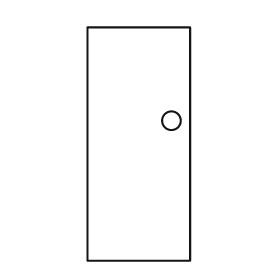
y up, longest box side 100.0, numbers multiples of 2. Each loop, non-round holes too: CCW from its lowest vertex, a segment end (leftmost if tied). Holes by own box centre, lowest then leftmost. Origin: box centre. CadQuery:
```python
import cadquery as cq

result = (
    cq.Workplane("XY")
    .moveTo(-22.0, -50.0)
    .lineTo(22.0, -50.0)
    .lineTo(22.0, 50.0)
    .lineTo(-22.0, 50.0)
    .close()
    .moveTo(14.0, 10.0)
    .circle(4.0)
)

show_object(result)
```